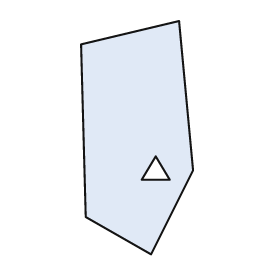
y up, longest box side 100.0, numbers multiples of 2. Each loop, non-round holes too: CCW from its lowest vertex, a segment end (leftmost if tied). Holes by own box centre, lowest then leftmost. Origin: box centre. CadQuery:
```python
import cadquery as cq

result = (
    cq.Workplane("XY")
    .moveTo(6.0, -50.0)
    .lineTo(24.0, -14.0)
    .lineTo(18.0, 50.0)
    .lineTo(-24.0, 40.0)
    .lineTo(-22.0, -34.0)
    .close()
    .moveTo(2.0, -18.0)
    .lineTo(14.0, -18.0)
    .lineTo(8.0, -8.0)
    .close()
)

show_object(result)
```